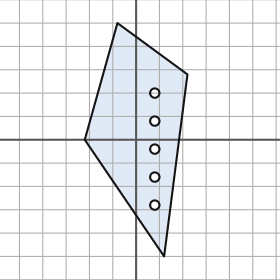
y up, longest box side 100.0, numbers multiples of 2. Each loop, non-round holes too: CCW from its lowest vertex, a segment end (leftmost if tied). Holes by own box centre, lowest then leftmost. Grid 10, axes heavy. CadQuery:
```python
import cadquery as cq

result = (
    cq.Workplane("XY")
    .moveTo(12.0, -50.0)
    .lineTo(22.0, 28.0)
    .lineTo(-8.0, 50.0)
    .lineTo(-22.0, 0.0)
    .close()
    .moveTo(8.0, -28.0)
    .circle(2.0)
    .moveTo(8.0, -16.0)
    .circle(2.0)
    .moveTo(8.0, -4.0)
    .circle(2.0)
    .moveTo(8.0, 8.0)
    .circle(2.0)
    .moveTo(8.0, 20.0)
    .circle(2.0)
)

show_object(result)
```